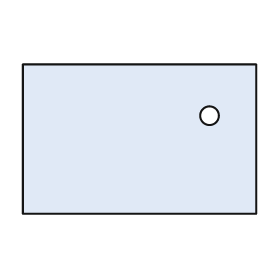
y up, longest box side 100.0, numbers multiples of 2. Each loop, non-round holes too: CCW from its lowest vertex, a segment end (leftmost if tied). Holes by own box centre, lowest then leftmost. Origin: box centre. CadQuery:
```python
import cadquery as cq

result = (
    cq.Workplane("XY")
    .moveTo(-50.0, -32.0)
    .lineTo(50.0, -32.0)
    .lineTo(50.0, 32.0)
    .lineTo(-50.0, 32.0)
    .close()
    .moveTo(30.0, 10.0)
    .circle(4.0)
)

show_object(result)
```